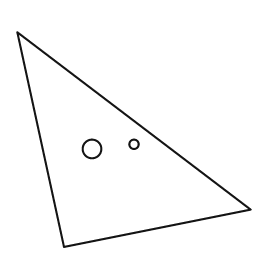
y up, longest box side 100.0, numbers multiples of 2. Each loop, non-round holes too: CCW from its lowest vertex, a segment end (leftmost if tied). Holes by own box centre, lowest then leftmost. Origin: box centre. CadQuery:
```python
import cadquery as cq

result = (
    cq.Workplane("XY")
    .moveTo(-30.0, -46.0)
    .lineTo(50.0, -30.0)
    .lineTo(-50.0, 46.0)
    .close()
    .moveTo(-18.0, -4.0)
    .circle(4.0)
    .moveTo(0.0, -2.0)
    .circle(2.0)
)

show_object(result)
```